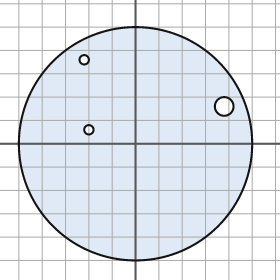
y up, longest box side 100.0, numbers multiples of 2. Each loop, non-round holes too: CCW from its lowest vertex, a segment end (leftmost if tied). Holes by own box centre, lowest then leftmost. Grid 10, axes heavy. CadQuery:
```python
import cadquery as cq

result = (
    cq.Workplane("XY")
    .moveTo(0.0, 0.0)
    .circle(50.0)
    .moveTo(-20.0, 6.0)
    .circle(2.0)
    .moveTo(38.0, 16.0)
    .circle(4.0)
    .moveTo(-22.0, 36.0)
    .circle(2.0)
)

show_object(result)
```